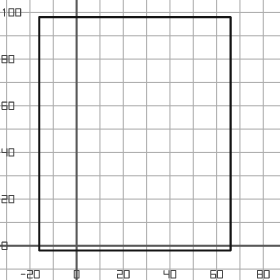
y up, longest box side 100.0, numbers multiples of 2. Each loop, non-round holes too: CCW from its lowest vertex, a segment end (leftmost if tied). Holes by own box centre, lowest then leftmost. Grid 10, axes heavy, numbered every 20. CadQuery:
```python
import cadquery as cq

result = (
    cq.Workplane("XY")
    .moveTo(-16.0, -2.0)
    .lineTo(66.0, -2.0)
    .lineTo(66.0, 98.0)
    .lineTo(-16.0, 98.0)
    .close()
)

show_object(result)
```